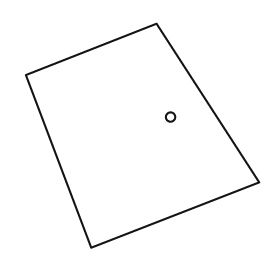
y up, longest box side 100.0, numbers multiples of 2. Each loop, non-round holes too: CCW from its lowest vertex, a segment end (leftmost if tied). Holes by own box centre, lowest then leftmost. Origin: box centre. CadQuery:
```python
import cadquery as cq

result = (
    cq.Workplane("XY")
    .moveTo(-22.0, -48.0)
    .lineTo(50.0, -20.0)
    .lineTo(6.0, 48.0)
    .lineTo(-50.0, 26.0)
    .close()
    .moveTo(12.0, 8.0)
    .circle(2.0)
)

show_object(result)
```